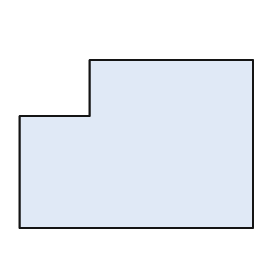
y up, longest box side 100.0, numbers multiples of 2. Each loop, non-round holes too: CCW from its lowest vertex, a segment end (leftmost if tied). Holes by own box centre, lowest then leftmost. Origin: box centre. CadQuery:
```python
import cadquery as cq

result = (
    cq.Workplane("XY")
    .moveTo(-50.0, -36.0)
    .lineTo(50.0, -36.0)
    .lineTo(50.0, 36.0)
    .lineTo(-20.0, 36.0)
    .lineTo(-20.0, 12.0)
    .lineTo(-50.0, 12.0)
    .close()
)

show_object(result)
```